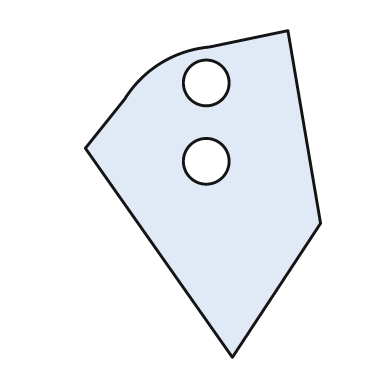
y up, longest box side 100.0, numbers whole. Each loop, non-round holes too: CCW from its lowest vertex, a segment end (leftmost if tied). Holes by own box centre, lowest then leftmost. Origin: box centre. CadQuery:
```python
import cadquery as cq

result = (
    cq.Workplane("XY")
    .moveTo(9.0, -50.0)
    .lineTo(36.0, -9.0)
    .lineTo(26.0, 50.0)
    .lineTo(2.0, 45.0)
    .threePointArc((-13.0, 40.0), (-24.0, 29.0))
    .lineTo(-36.0, 14.0)
    .close()
    .moveTo(1.0, 10.0)
    .circle(7.0)
    .moveTo(1.0, 34.0)
    .circle(7.0)
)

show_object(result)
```